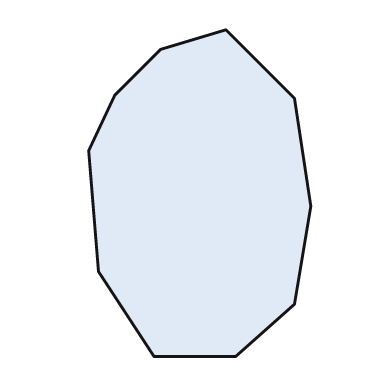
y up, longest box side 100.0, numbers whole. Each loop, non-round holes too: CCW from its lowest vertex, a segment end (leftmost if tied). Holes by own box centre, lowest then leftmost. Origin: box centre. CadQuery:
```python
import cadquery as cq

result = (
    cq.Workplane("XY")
    .moveTo(-14.0, -50.0)
    .lineTo(11.0, -50.0)
    .lineTo(29.0, -34.0)
    .lineTo(34.0, -4.0)
    .lineTo(29.0, 29.0)
    .lineTo(8.0, 50.0)
    .lineTo(-12.0, 44.0)
    .lineTo(-26.0, 30.0)
    .lineTo(-34.0, 13.0)
    .lineTo(-31.0, -24.0)
    .close()
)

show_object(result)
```